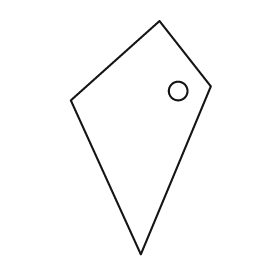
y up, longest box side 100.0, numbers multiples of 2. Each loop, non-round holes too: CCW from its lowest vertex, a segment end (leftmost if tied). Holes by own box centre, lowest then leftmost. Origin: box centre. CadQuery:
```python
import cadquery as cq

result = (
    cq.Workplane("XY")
    .moveTo(0.0, -50.0)
    .lineTo(30.0, 22.0)
    .lineTo(8.0, 50.0)
    .lineTo(-30.0, 16.0)
    .close()
    .moveTo(16.0, 20.0)
    .circle(4.0)
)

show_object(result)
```